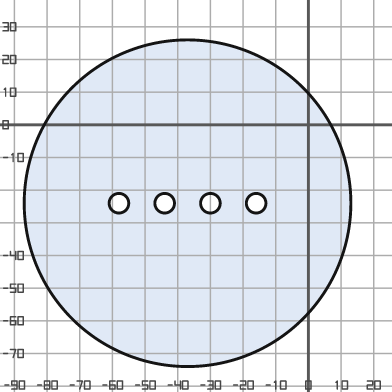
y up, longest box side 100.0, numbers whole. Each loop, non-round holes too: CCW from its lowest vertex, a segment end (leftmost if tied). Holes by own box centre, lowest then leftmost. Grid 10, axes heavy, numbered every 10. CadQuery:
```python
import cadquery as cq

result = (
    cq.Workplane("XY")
    .moveTo(-37.0, -24.0)
    .circle(50.0)
    .moveTo(-58.0, -24.0)
    .circle(3.0)
    .moveTo(-44.0, -24.0)
    .circle(3.0)
    .moveTo(-30.0, -24.0)
    .circle(3.0)
    .moveTo(-16.0, -24.0)
    .circle(3.0)
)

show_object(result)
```